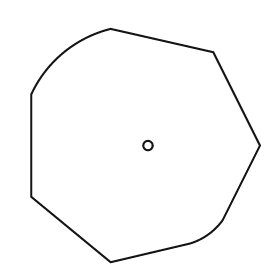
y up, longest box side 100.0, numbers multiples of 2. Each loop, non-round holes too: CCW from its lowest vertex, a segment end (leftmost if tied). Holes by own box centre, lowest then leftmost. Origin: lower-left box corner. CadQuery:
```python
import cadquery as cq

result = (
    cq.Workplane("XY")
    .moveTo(34.0, 0.0)
    .lineTo(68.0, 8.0)
    .threePointArc((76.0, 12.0), (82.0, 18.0))
    .lineTo(98.0, 50.0)
    .lineTo(78.0, 90.0)
    .lineTo(34.0, 100.0)
    .threePointArc((14.0, 90.0), (0.0, 72.0))
    .lineTo(0.0, 28.0)
    .close()
    .moveTo(50.0, 50.0)
    .circle(2.0)
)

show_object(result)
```